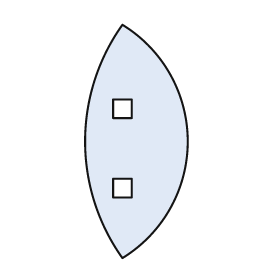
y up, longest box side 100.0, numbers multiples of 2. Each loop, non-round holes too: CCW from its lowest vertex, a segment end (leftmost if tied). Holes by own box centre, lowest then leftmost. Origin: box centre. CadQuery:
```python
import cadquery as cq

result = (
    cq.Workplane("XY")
    .moveTo(-6.0, -50.0)
    .threePointArc((22.0, 0.0), (-6.0, 50.0))
    .threePointArc((-22.0, 0.0), (-6.0, -50.0))
    .close()
    .moveTo(-10.0, -24.0)
    .lineTo(-2.0, -24.0)
    .lineTo(-2.0, -16.0)
    .lineTo(-10.0, -16.0)
    .close()
    .moveTo(-10.0, 10.0)
    .lineTo(-2.0, 10.0)
    .lineTo(-2.0, 18.0)
    .lineTo(-10.0, 18.0)
    .close()
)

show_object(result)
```